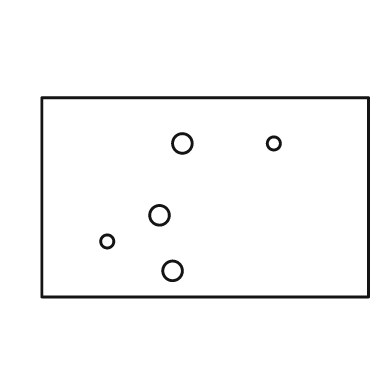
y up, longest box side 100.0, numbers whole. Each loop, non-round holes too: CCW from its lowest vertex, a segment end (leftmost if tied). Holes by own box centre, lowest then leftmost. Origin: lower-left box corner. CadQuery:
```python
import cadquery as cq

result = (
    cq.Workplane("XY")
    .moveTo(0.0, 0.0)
    .lineTo(100.0, 0.0)
    .lineTo(100.0, 61.0)
    .lineTo(0.0, 61.0)
    .close()
    .moveTo(40.0, 8.0)
    .circle(3.0)
    .moveTo(20.0, 17.0)
    .circle(2.0)
    .moveTo(36.0, 25.0)
    .circle(3.0)
    .moveTo(43.0, 47.0)
    .circle(3.0)
    .moveTo(71.0, 47.0)
    .circle(2.0)
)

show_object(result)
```